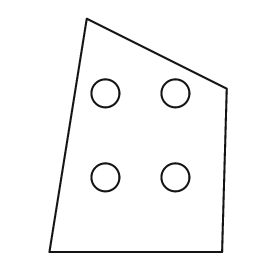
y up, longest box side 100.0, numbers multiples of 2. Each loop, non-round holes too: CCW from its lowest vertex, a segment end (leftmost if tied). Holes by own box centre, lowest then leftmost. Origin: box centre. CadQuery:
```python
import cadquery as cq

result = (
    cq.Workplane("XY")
    .moveTo(-38.0, -50.0)
    .lineTo(36.0, -50.0)
    .lineTo(38.0, 20.0)
    .lineTo(-22.0, 50.0)
    .close()
    .moveTo(-14.0, -18.0)
    .circle(6.0)
    .moveTo(16.0, -18.0)
    .circle(6.0)
    .moveTo(-14.0, 18.0)
    .circle(6.0)
    .moveTo(16.0, 18.0)
    .circle(6.0)
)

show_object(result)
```